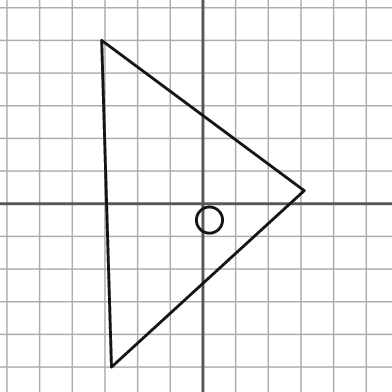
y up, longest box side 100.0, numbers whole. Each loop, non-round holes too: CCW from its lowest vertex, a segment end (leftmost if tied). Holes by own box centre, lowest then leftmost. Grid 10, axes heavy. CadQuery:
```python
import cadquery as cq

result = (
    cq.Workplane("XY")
    .moveTo(-28.0, -50.0)
    .lineTo(31.0, 4.0)
    .lineTo(-31.0, 50.0)
    .close()
    .moveTo(2.0, -5.0)
    .circle(4.0)
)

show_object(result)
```